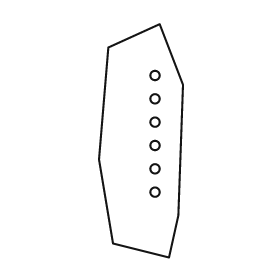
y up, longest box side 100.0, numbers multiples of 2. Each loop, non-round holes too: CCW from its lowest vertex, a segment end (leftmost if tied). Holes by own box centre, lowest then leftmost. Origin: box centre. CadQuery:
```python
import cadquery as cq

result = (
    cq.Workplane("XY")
    .moveTo(12.0, -50.0)
    .lineTo(16.0, -32.0)
    .lineTo(18.0, 24.0)
    .lineTo(8.0, 50.0)
    .lineTo(-14.0, 40.0)
    .lineTo(-18.0, -8.0)
    .lineTo(-12.0, -44.0)
    .close()
    .moveTo(6.0, -22.0)
    .circle(2.0)
    .moveTo(6.0, -12.0)
    .circle(2.0)
    .moveTo(6.0, -2.0)
    .circle(2.0)
    .moveTo(6.0, 8.0)
    .circle(2.0)
    .moveTo(6.0, 18.0)
    .circle(2.0)
    .moveTo(6.0, 28.0)
    .circle(2.0)
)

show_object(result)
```